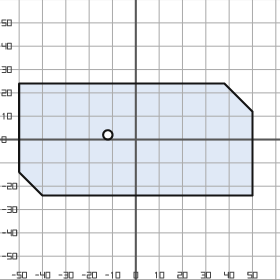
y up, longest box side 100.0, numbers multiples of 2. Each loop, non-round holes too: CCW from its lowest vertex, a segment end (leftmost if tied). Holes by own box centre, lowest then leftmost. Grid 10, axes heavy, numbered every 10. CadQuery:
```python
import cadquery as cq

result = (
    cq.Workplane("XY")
    .moveTo(-40.0, -24.0)
    .lineTo(50.0, -24.0)
    .lineTo(50.0, 12.0)
    .lineTo(38.0, 24.0)
    .lineTo(-50.0, 24.0)
    .lineTo(-50.0, -14.0)
    .close()
    .moveTo(-12.0, 2.0)
    .circle(2.0)
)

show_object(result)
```